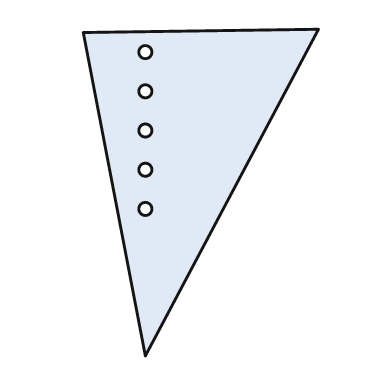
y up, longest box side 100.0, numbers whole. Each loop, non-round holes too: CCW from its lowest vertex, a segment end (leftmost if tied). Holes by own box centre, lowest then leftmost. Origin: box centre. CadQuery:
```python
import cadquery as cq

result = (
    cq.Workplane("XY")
    .moveTo(-17.0, -50.0)
    .lineTo(36.0, 50.0)
    .lineTo(-36.0, 49.0)
    .close()
    .moveTo(-17.0, -5.0)
    .circle(2.0)
    .moveTo(-17.0, 7.0)
    .circle(2.0)
    .moveTo(-17.0, 19.0)
    .circle(2.0)
    .moveTo(-17.0, 31.0)
    .circle(2.0)
    .moveTo(-17.0, 43.0)
    .circle(2.0)
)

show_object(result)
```